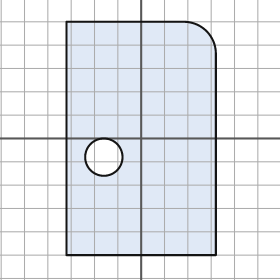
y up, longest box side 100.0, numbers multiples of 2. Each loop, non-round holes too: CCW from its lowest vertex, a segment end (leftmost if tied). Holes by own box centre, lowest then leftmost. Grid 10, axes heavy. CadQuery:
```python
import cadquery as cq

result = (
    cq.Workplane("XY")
    .moveTo(-32.0, -50.0)
    .lineTo(32.0, -50.0)
    .lineTo(32.0, 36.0)
    .threePointArc((28.0, 46.0), (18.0, 50.0))
    .lineTo(-32.0, 50.0)
    .close()
    .moveTo(-16.0, -8.0)
    .circle(8.0)
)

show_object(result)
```